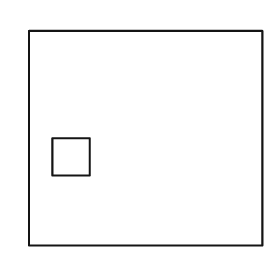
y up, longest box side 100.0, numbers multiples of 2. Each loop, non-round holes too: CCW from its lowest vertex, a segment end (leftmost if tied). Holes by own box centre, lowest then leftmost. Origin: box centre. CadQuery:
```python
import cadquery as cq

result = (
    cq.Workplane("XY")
    .moveTo(-50.0, -46.0)
    .lineTo(50.0, -46.0)
    .lineTo(50.0, 46.0)
    .lineTo(-50.0, 46.0)
    .close()
    .moveTo(-40.0, -16.0)
    .lineTo(-24.0, -16.0)
    .lineTo(-24.0, 0.0)
    .lineTo(-40.0, 0.0)
    .close()
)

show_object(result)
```